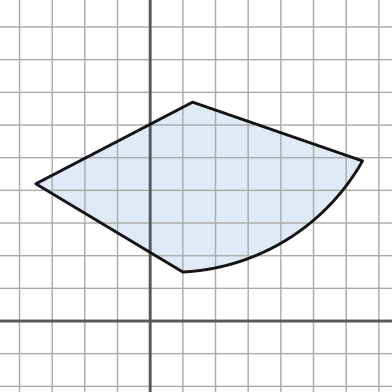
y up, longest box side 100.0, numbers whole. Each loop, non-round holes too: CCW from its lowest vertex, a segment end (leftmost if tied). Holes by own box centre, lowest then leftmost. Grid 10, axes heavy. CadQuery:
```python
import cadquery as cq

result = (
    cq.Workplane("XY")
    .moveTo(10.0, 15.0)
    .threePointArc((42.0, 25.0), (65.0, 49.0))
    .lineTo(13.0, 67.0)
    .lineTo(-35.0, 42.0)
    .close()
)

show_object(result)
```